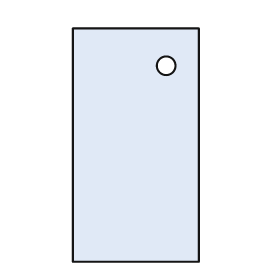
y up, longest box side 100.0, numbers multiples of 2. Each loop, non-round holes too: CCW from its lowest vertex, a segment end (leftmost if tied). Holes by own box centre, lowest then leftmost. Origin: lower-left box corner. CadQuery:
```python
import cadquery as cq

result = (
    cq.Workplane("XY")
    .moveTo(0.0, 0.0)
    .lineTo(54.0, 0.0)
    .lineTo(54.0, 100.0)
    .lineTo(0.0, 100.0)
    .close()
    .moveTo(40.0, 84.0)
    .circle(4.0)
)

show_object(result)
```